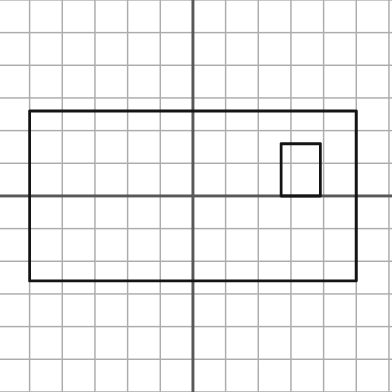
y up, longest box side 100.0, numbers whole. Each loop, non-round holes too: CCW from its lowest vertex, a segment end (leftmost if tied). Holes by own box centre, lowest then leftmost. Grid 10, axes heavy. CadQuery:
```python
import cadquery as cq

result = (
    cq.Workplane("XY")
    .moveTo(-50.0, -26.0)
    .lineTo(50.0, -26.0)
    .lineTo(50.0, 26.0)
    .lineTo(-50.0, 26.0)
    .close()
    .moveTo(27.0, 0.0)
    .lineTo(39.0, 0.0)
    .lineTo(39.0, 16.0)
    .lineTo(27.0, 16.0)
    .close()
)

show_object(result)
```